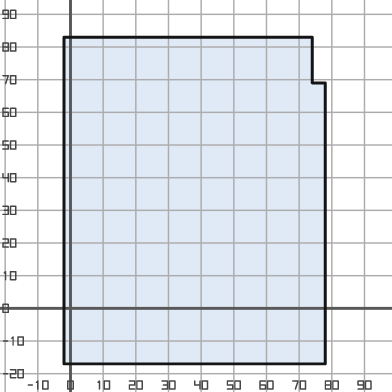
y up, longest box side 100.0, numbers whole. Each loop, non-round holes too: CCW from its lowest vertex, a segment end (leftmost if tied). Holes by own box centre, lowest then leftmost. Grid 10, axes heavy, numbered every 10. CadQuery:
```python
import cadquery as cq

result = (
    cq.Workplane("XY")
    .moveTo(-2.0, -17.0)
    .lineTo(78.0, -17.0)
    .lineTo(78.0, 69.0)
    .lineTo(74.0, 69.0)
    .lineTo(74.0, 83.0)
    .lineTo(-2.0, 83.0)
    .close()
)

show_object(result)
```